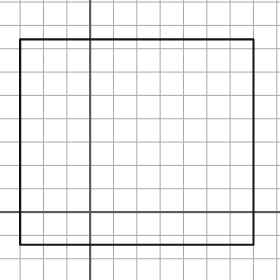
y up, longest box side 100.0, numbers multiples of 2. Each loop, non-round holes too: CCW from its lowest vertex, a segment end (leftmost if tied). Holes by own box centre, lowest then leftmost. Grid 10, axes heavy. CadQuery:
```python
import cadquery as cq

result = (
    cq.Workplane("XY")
    .moveTo(-30.0, -14.0)
    .lineTo(70.0, -14.0)
    .lineTo(70.0, 74.0)
    .lineTo(-30.0, 74.0)
    .close()
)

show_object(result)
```